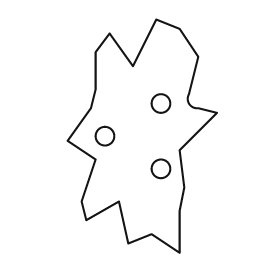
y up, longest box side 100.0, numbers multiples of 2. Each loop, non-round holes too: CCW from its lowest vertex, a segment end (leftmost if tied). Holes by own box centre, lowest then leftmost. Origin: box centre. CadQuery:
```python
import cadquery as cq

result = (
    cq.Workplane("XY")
    .moveTo(16.0, -50.0)
    .lineTo(16.0, -32.0)
    .lineTo(18.0, -22.0)
    .lineTo(16.0, -6.0)
    .lineTo(32.0, 10.0)
    .lineTo(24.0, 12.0)
    .threePointArc((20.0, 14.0), (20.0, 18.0))
    .lineTo(24.0, 34.0)
    .lineTo(16.0, 46.0)
    .lineTo(6.0, 50.0)
    .lineTo(-4.0, 30.0)
    .lineTo(-14.0, 44.0)
    .lineTo(-20.0, 36.0)
    .lineTo(-20.0, 20.0)
    .lineTo(-22.0, 12.0)
    .lineTo(-32.0, -2.0)
    .lineTo(-20.0, -10.0)
    .lineTo(-26.0, -28.0)
    .lineTo(-24.0, -36.0)
    .lineTo(-10.0, -28.0)
    .lineTo(-6.0, -46.0)
    .lineTo(4.0, -42.0)
    .close()
    .moveTo(8.0, -14.0)
    .circle(4.0)
    .moveTo(-16.0, 0.0)
    .circle(4.0)
    .moveTo(8.0, 14.0)
    .circle(4.0)
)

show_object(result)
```